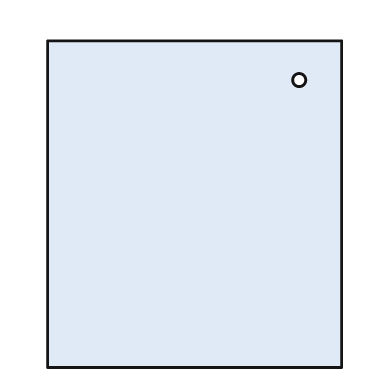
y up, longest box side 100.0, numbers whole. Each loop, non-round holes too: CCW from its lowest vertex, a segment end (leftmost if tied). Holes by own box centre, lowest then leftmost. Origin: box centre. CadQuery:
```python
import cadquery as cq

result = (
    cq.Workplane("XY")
    .moveTo(-45.0, -50.0)
    .lineTo(45.0, -50.0)
    .lineTo(45.0, 50.0)
    .lineTo(-45.0, 50.0)
    .close()
    .moveTo(32.0, 38.0)
    .circle(2.0)
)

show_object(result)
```